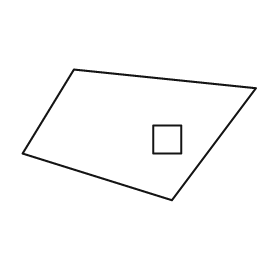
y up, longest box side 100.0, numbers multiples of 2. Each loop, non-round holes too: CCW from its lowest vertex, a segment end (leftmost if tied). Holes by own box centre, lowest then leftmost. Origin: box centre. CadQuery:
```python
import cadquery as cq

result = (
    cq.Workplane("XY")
    .moveTo(14.0, -28.0)
    .lineTo(50.0, 20.0)
    .lineTo(-28.0, 28.0)
    .lineTo(-50.0, -8.0)
    .close()
    .moveTo(6.0, -8.0)
    .lineTo(18.0, -8.0)
    .lineTo(18.0, 4.0)
    .lineTo(6.0, 4.0)
    .close()
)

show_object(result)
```